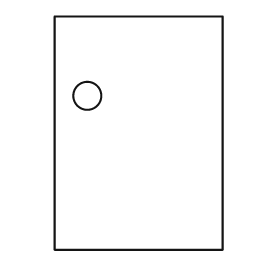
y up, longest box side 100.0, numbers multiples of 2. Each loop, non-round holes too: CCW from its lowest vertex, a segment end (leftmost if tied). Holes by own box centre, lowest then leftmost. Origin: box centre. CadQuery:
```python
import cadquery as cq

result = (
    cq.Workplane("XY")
    .moveTo(-36.0, -50.0)
    .lineTo(36.0, -50.0)
    .lineTo(36.0, 50.0)
    .lineTo(-36.0, 50.0)
    .close()
    .moveTo(-22.0, 16.0)
    .circle(6.0)
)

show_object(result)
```